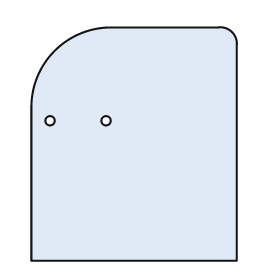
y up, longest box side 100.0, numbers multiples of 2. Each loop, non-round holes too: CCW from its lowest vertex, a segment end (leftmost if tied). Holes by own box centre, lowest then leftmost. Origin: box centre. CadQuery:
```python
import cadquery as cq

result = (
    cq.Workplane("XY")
    .moveTo(-44.0, -50.0)
    .lineTo(44.0, -50.0)
    .lineTo(44.0, 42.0)
    .threePointArc((42.0, 48.0), (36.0, 50.0))
    .lineTo(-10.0, 50.0)
    .threePointArc((-34.0, 40.0), (-44.0, 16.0))
    .close()
    .moveTo(-36.0, 10.0)
    .circle(2.0)
    .moveTo(-12.0, 10.0)
    .circle(2.0)
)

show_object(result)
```